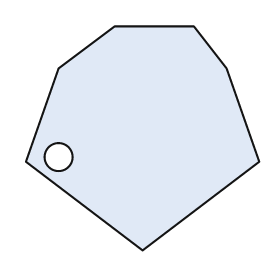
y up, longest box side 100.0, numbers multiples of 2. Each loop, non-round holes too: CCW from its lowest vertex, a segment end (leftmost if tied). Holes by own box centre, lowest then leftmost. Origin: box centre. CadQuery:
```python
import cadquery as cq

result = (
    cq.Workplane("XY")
    .moveTo(0.0, -48.0)
    .lineTo(50.0, -10.0)
    .lineTo(36.0, 30.0)
    .lineTo(22.0, 48.0)
    .lineTo(-12.0, 48.0)
    .lineTo(-36.0, 30.0)
    .lineTo(-50.0, -10.0)
    .close()
    .moveTo(-36.0, -8.0)
    .circle(6.0)
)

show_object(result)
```